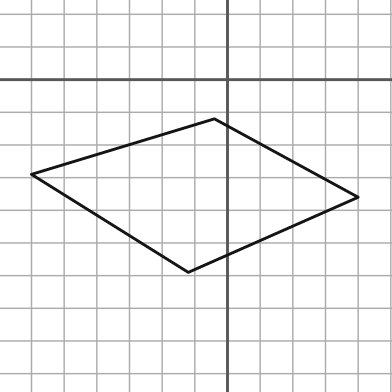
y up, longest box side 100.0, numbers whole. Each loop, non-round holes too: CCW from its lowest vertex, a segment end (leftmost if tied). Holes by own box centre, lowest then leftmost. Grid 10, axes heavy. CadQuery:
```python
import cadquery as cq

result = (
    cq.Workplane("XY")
    .moveTo(-12.0, -59.0)
    .lineTo(40.0, -36.0)
    .lineTo(-4.0, -12.0)
    .lineTo(-60.0, -29.0)
    .close()
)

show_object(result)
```